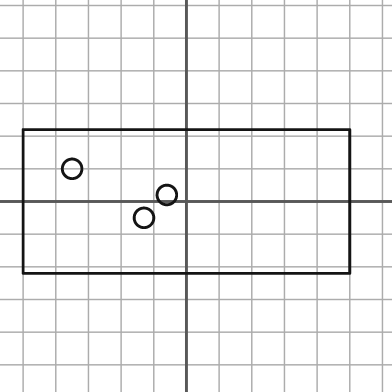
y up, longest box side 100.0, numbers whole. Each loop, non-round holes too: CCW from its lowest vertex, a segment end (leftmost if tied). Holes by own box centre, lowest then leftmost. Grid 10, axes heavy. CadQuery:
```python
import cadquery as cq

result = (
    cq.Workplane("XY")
    .moveTo(-50.0, -22.0)
    .lineTo(50.0, -22.0)
    .lineTo(50.0, 22.0)
    .lineTo(-50.0, 22.0)
    .close()
    .moveTo(-13.0, -5.0)
    .circle(3.0)
    .moveTo(-6.0, 2.0)
    .circle(3.0)
    .moveTo(-35.0, 10.0)
    .circle(3.0)
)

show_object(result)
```